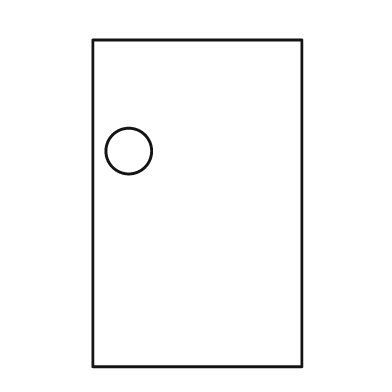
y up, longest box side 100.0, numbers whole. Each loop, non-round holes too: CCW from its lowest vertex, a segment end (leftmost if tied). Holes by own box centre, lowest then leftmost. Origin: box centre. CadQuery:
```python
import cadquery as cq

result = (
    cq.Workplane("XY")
    .moveTo(-32.0, -50.0)
    .lineTo(32.0, -50.0)
    .lineTo(32.0, 50.0)
    .lineTo(-32.0, 50.0)
    .close()
    .moveTo(-21.0, 16.0)
    .circle(7.0)
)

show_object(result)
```